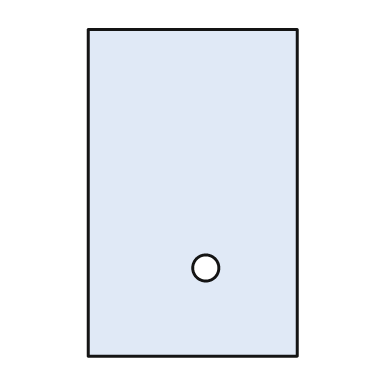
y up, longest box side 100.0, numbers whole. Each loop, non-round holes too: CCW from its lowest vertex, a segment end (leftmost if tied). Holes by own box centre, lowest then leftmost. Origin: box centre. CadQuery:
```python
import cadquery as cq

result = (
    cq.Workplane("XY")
    .moveTo(-32.0, -50.0)
    .lineTo(32.0, -50.0)
    .lineTo(32.0, 50.0)
    .lineTo(-32.0, 50.0)
    .close()
    .moveTo(4.0, -23.0)
    .circle(4.0)
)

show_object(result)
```